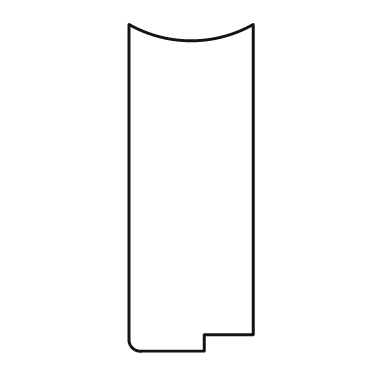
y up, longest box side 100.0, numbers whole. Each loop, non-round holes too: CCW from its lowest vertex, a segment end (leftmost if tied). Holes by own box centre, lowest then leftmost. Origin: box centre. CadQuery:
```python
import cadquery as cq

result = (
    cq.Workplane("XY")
    .moveTo(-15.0, -50.0)
    .lineTo(4.0, -50.0)
    .lineTo(4.0, -45.0)
    .lineTo(19.0, -45.0)
    .lineTo(19.0, 50.0)
    .threePointArc((0.0, 45.0), (-19.0, 50.0))
    .lineTo(-19.0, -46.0)
    .threePointArc((-18.0, -49.0), (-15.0, -50.0))
    .close()
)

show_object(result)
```